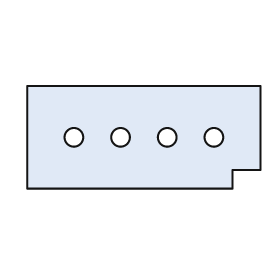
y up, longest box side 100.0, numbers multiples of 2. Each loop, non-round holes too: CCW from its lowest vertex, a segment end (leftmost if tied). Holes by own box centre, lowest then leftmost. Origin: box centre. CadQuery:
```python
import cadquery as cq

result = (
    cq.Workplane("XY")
    .moveTo(-50.0, -22.0)
    .lineTo(38.0, -22.0)
    .lineTo(38.0, -14.0)
    .lineTo(50.0, -14.0)
    .lineTo(50.0, 22.0)
    .lineTo(-50.0, 22.0)
    .close()
    .moveTo(-30.0, 0.0)
    .circle(4.0)
    .moveTo(-10.0, 0.0)
    .circle(4.0)
    .moveTo(10.0, 0.0)
    .circle(4.0)
    .moveTo(30.0, 0.0)
    .circle(4.0)
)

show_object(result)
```